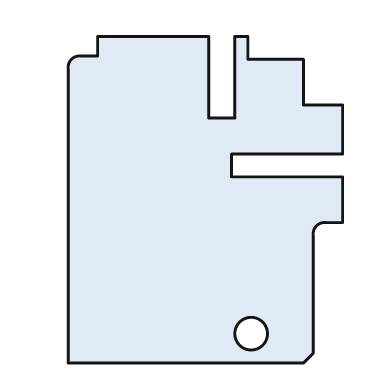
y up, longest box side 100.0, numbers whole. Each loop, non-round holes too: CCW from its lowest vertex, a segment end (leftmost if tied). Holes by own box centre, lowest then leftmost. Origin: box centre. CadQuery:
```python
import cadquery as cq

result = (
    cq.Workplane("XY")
    .moveTo(-42.0, -50.0)
    .lineTo(30.0, -50.0)
    .lineTo(33.0, -47.0)
    .lineTo(33.0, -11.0)
    .threePointArc((34.0, -8.0), (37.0, -7.0))
    .lineTo(42.0, -7.0)
    .lineTo(42.0, 7.0)
    .lineTo(8.0, 7.0)
    .lineTo(8.0, 14.0)
    .lineTo(42.0, 14.0)
    .lineTo(42.0, 29.0)
    .lineTo(30.0, 29.0)
    .lineTo(30.0, 43.0)
    .lineTo(13.0, 43.0)
    .lineTo(13.0, 50.0)
    .lineTo(9.0, 50.0)
    .lineTo(9.0, 25.0)
    .lineTo(1.0, 25.0)
    .lineTo(1.0, 50.0)
    .lineTo(-33.0, 50.0)
    .lineTo(-33.0, 44.0)
    .lineTo(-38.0, 44.0)
    .threePointArc((-41.0, 43.0), (-42.0, 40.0))
    .close()
    .moveTo(14.0, -41.0)
    .circle(5.0)
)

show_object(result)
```